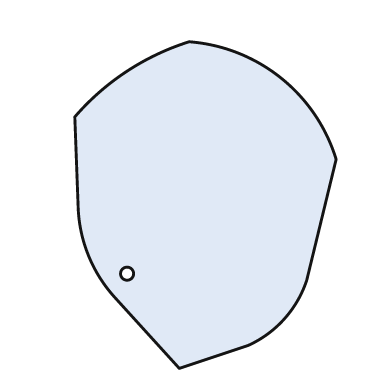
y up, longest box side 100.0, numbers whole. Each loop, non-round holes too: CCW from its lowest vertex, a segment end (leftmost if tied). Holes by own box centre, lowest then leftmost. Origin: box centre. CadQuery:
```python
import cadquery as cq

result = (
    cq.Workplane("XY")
    .moveTo(-8.0, -50.0)
    .lineTo(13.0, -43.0)
    .threePointArc((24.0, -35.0), (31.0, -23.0))
    .lineTo(40.0, 14.0)
    .threePointArc((23.0, 39.0), (-5.0, 50.0))
    .threePointArc((-24.0, 41.0), (-40.0, 27.0))
    .lineTo(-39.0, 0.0)
    .threePointArc((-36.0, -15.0), (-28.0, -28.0))
    .close()
    .moveTo(-24.0, -21.0)
    .circle(2.0)
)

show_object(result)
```